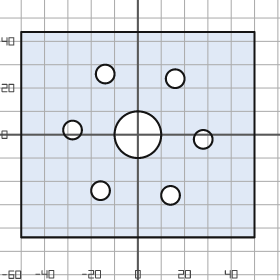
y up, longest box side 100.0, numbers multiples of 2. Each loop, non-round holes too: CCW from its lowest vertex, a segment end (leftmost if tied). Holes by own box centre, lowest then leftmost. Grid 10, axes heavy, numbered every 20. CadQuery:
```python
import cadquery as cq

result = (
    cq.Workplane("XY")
    .moveTo(-50.0, -44.0)
    .lineTo(50.0, -44.0)
    .lineTo(50.0, 44.0)
    .lineTo(-50.0, 44.0)
    .close()
    .moveTo(14.0, -26.0)
    .circle(4.0)
    .moveTo(-16.0, -24.0)
    .circle(4.0)
    .moveTo(28.0, -2.0)
    .circle(4.0)
    .moveTo(0.0, 0.0)
    .circle(10.0)
    .moveTo(-28.0, 2.0)
    .circle(4.0)
    .moveTo(16.0, 24.0)
    .circle(4.0)
    .moveTo(-14.0, 26.0)
    .circle(4.0)
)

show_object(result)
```